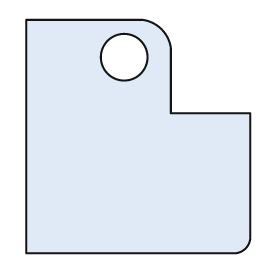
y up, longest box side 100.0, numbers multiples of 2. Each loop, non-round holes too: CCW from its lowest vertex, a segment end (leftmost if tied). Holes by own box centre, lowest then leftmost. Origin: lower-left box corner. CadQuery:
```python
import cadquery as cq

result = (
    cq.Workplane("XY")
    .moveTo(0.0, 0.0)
    .lineTo(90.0, 0.0)
    .threePointArc((94.0, 2.0), (96.0, 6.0))
    .lineTo(96.0, 60.0)
    .lineTo(62.0, 60.0)
    .lineTo(62.0, 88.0)
    .threePointArc((58.0, 96.0), (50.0, 100.0))
    .lineTo(0.0, 100.0)
    .close()
    .moveTo(42.0, 84.0)
    .circle(10.0)
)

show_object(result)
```